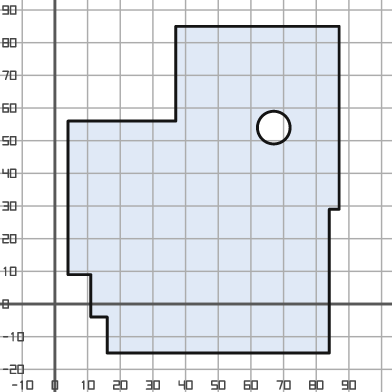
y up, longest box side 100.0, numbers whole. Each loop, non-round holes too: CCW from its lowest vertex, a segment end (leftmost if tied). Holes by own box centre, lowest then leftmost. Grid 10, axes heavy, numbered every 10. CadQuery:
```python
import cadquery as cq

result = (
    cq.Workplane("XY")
    .moveTo(16.0, -15.0)
    .lineTo(84.0, -15.0)
    .lineTo(84.0, 29.0)
    .lineTo(87.0, 29.0)
    .lineTo(87.0, 85.0)
    .lineTo(37.0, 85.0)
    .lineTo(37.0, 56.0)
    .lineTo(4.0, 56.0)
    .lineTo(4.0, 9.0)
    .lineTo(11.0, 9.0)
    .lineTo(11.0, -4.0)
    .lineTo(16.0, -4.0)
    .close()
    .moveTo(67.0, 54.0)
    .circle(5.0)
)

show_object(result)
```